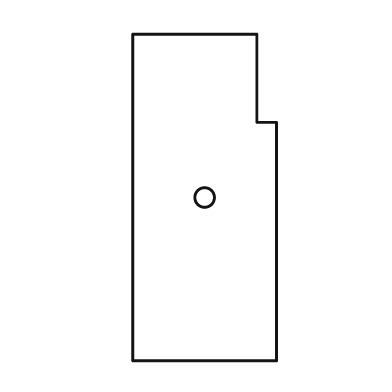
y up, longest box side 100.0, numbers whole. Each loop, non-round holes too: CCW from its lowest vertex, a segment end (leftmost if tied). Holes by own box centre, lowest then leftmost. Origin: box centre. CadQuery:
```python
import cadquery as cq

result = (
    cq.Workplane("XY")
    .moveTo(-22.0, -50.0)
    .lineTo(22.0, -50.0)
    .lineTo(22.0, 23.0)
    .lineTo(16.0, 23.0)
    .lineTo(16.0, 50.0)
    .lineTo(-22.0, 50.0)
    .close()
    .moveTo(0.0, 0.0)
    .circle(3.0)
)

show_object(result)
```